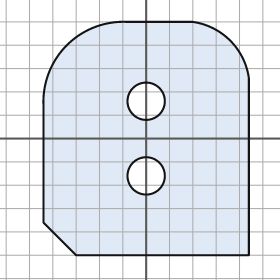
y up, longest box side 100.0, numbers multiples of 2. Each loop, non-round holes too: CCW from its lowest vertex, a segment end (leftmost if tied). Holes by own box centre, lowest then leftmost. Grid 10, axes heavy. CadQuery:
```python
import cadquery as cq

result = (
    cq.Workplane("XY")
    .moveTo(-30.0, -50.0)
    .lineTo(44.0, -50.0)
    .lineTo(44.0, 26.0)
    .threePointArc((36.0, 42.0), (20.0, 50.0))
    .lineTo(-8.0, 50.0)
    .threePointArc((-34.0, 40.0), (-44.0, 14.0))
    .lineTo(-44.0, -36.0)
    .close()
    .moveTo(0.0, -16.0)
    .circle(8.0)
    .moveTo(0.0, 16.0)
    .circle(8.0)
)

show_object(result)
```